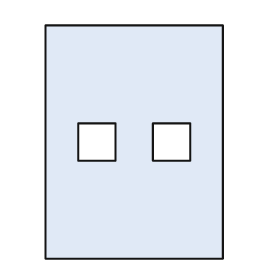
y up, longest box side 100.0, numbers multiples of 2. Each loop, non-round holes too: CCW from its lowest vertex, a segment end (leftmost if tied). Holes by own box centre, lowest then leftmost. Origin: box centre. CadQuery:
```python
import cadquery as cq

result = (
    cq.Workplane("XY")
    .moveTo(-38.0, -50.0)
    .lineTo(38.0, -50.0)
    .lineTo(38.0, 50.0)
    .lineTo(-38.0, 50.0)
    .close()
    .moveTo(-24.0, -8.0)
    .lineTo(-8.0, -8.0)
    .lineTo(-8.0, 8.0)
    .lineTo(-24.0, 8.0)
    .close()
    .moveTo(8.0, -8.0)
    .lineTo(24.0, -8.0)
    .lineTo(24.0, 8.0)
    .lineTo(8.0, 8.0)
    .close()
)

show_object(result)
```